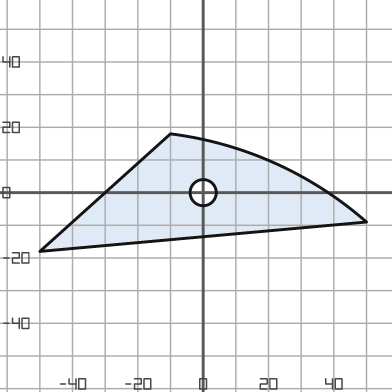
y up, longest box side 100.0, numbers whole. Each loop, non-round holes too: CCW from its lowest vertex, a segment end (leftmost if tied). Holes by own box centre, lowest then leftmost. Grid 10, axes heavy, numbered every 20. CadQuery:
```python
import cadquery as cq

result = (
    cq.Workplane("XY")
    .moveTo(-50.0, -18.0)
    .lineTo(50.0, -9.0)
    .threePointArc((22.0, 9.0), (-10.0, 18.0))
    .close()
    .moveTo(0.0, 0.0)
    .circle(4.0)
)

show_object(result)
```